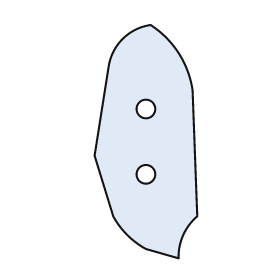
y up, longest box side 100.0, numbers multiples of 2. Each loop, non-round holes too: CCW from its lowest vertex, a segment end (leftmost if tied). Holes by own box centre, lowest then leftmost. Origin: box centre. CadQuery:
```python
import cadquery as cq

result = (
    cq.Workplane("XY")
    .moveTo(14.0, -50.0)
    .threePointArc((16.0, -40.0), (22.0, -32.0))
    .lineTo(20.0, 22.0)
    .threePointArc((14.0, 38.0), (2.0, 50.0))
    .threePointArc((-10.0, 44.0), (-16.0, 32.0))
    .lineTo(-22.0, -6.0)
    .lineTo(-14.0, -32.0)
    .threePointArc((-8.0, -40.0), (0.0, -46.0))
    .close()
    .moveTo(0.0, -14.0)
    .circle(4.0)
    .moveTo(0.0, 14.0)
    .circle(4.0)
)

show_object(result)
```